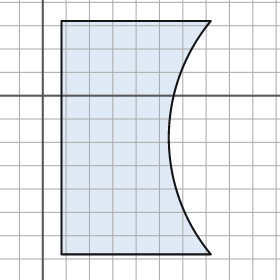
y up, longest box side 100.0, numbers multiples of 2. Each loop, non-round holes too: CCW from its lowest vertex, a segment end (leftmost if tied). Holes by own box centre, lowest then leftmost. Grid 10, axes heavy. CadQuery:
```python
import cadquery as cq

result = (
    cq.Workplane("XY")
    .moveTo(8.0, -68.0)
    .lineTo(72.0, -68.0)
    .threePointArc((54.0, -18.0), (72.0, 32.0))
    .lineTo(8.0, 32.0)
    .close()
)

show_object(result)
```